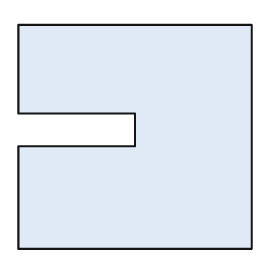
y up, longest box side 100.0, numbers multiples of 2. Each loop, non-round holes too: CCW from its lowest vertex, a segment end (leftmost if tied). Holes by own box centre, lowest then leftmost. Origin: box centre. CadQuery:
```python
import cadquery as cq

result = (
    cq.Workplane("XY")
    .moveTo(-50.0, -48.0)
    .lineTo(50.0, -48.0)
    .lineTo(50.0, 48.0)
    .lineTo(-50.0, 48.0)
    .lineTo(-50.0, 10.0)
    .lineTo(0.0, 10.0)
    .lineTo(0.0, -4.0)
    .lineTo(-50.0, -4.0)
    .close()
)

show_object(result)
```